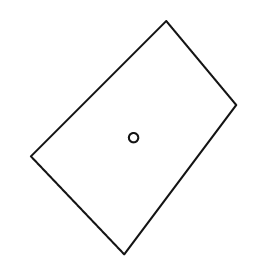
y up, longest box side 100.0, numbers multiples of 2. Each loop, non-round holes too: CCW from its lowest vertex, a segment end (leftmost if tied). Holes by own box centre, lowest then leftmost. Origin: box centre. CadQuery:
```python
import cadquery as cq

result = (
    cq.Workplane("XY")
    .moveTo(-4.0, -50.0)
    .lineTo(44.0, 14.0)
    .lineTo(14.0, 50.0)
    .lineTo(-44.0, -8.0)
    .close()
    .moveTo(0.0, 0.0)
    .circle(2.0)
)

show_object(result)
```